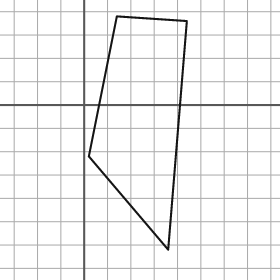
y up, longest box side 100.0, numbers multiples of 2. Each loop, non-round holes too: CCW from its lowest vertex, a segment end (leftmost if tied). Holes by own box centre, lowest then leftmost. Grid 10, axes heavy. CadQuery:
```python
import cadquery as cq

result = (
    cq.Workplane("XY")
    .moveTo(36.0, -62.0)
    .lineTo(44.0, 36.0)
    .lineTo(14.0, 38.0)
    .lineTo(2.0, -22.0)
    .close()
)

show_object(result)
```